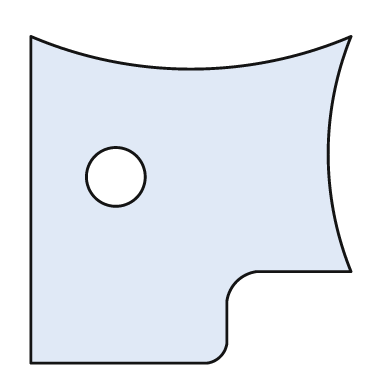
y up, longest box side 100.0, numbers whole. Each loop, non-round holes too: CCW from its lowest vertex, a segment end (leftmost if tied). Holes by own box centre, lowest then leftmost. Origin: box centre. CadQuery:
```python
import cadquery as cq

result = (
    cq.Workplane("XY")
    .moveTo(-49.0, -50.0)
    .lineTo(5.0, -50.0)
    .threePointArc((9.0, -48.0), (11.0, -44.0))
    .lineTo(11.0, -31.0)
    .threePointArc((14.0, -25.0), (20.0, -22.0))
    .lineTo(49.0, -22.0)
    .threePointArc((42.0, 14.0), (49.0, 50.0))
    .threePointArc((0.0, 40.0), (-49.0, 50.0))
    .close()
    .moveTo(-23.0, 7.0)
    .circle(9.0)
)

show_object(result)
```